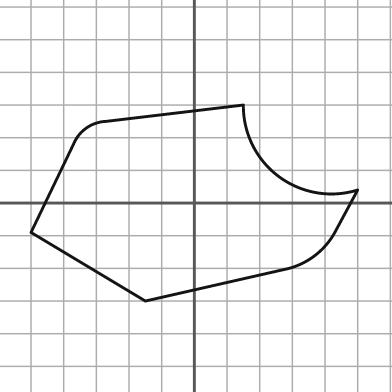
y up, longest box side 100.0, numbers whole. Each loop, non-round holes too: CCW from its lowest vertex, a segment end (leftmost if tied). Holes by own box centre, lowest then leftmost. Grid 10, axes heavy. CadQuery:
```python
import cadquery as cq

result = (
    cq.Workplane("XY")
    .moveTo(-15.0, -30.0)
    .lineTo(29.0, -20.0)
    .threePointArc((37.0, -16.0), (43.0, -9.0))
    .lineTo(50.0, 4.0)
    .threePointArc((26.0, 8.0), (15.0, 30.0))
    .lineTo(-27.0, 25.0)
    .threePointArc((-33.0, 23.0), (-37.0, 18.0))
    .lineTo(-50.0, -9.0)
    .close()
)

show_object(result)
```